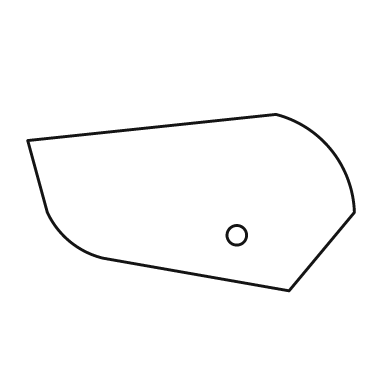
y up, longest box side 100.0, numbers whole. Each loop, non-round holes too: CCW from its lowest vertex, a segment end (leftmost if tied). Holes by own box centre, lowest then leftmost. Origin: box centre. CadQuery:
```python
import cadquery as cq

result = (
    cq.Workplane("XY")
    .moveTo(30.0, -27.0)
    .lineTo(50.0, -3.0)
    .threePointArc((43.0, 16.0), (26.0, 27.0))
    .lineTo(-50.0, 19.0)
    .lineTo(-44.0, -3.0)
    .threePointArc((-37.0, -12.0), (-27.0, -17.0))
    .close()
    .moveTo(14.0, -10.0)
    .circle(3.0)
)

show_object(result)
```